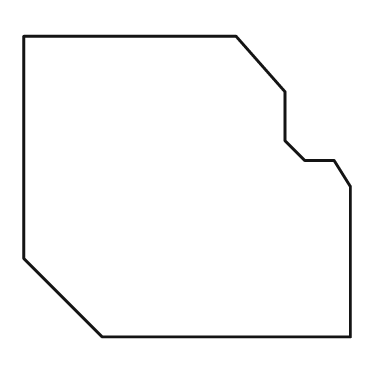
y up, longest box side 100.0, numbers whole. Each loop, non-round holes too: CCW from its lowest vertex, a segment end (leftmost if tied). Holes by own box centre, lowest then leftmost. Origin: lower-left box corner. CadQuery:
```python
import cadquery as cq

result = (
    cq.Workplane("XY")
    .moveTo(24.0, 0.0)
    .lineTo(100.0, 0.0)
    .lineTo(100.0, 46.0)
    .lineTo(95.0, 54.0)
    .lineTo(86.0, 54.0)
    .lineTo(80.0, 60.0)
    .lineTo(80.0, 75.0)
    .lineTo(65.0, 92.0)
    .lineTo(0.0, 92.0)
    .lineTo(0.0, 24.0)
    .close()
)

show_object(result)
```